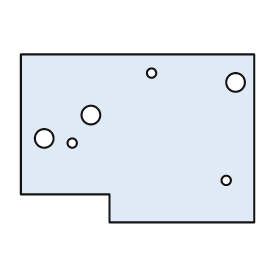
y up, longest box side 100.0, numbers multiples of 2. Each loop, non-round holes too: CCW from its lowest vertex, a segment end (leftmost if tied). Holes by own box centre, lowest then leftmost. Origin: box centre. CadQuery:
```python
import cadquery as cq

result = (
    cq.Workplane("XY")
    .moveTo(-12.0, -36.0)
    .lineTo(50.0, -36.0)
    .lineTo(50.0, 36.0)
    .lineTo(-50.0, 36.0)
    .lineTo(-50.0, -24.0)
    .lineTo(-12.0, -24.0)
    .close()
    .moveTo(38.0, -18.0)
    .circle(2.0)
    .moveTo(-28.0, -2.0)
    .circle(2.0)
    .moveTo(-40.0, 0.0)
    .circle(4.0)
    .moveTo(-20.0, 10.0)
    .circle(4.0)
    .moveTo(42.0, 24.0)
    .circle(4.0)
    .moveTo(6.0, 28.0)
    .circle(2.0)
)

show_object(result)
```